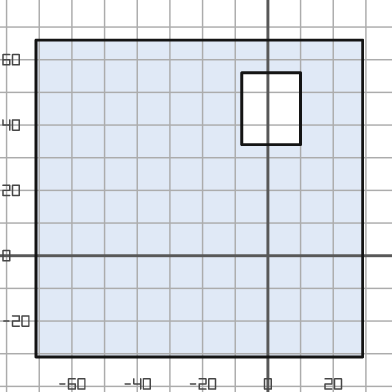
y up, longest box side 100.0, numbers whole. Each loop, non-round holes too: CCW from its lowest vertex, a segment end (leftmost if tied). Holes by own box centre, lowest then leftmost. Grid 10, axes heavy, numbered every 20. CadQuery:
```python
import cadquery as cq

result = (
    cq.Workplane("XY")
    .moveTo(-71.0, -31.0)
    .lineTo(29.0, -31.0)
    .lineTo(29.0, 66.0)
    .lineTo(-71.0, 66.0)
    .close()
    .moveTo(-8.0, 34.0)
    .lineTo(10.0, 34.0)
    .lineTo(10.0, 56.0)
    .lineTo(-8.0, 56.0)
    .close()
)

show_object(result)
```